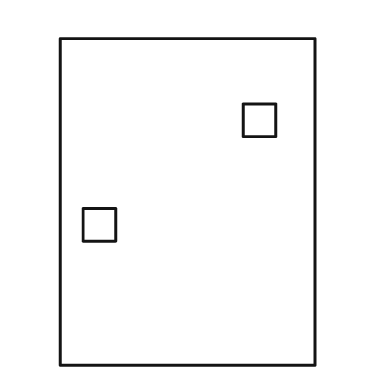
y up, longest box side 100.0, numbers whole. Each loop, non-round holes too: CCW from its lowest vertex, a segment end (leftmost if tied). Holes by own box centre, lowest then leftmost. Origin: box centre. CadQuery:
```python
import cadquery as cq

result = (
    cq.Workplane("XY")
    .moveTo(-39.0, -50.0)
    .lineTo(39.0, -50.0)
    .lineTo(39.0, 50.0)
    .lineTo(-39.0, 50.0)
    .close()
    .moveTo(-32.0, -12.0)
    .lineTo(-22.0, -12.0)
    .lineTo(-22.0, -2.0)
    .lineTo(-32.0, -2.0)
    .close()
    .moveTo(17.0, 20.0)
    .lineTo(27.0, 20.0)
    .lineTo(27.0, 30.0)
    .lineTo(17.0, 30.0)
    .close()
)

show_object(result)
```